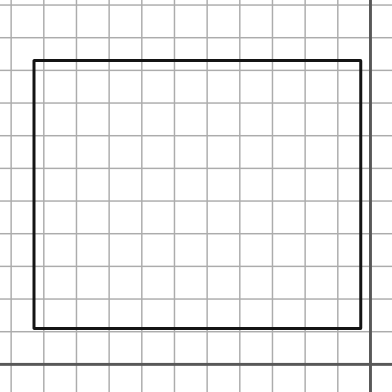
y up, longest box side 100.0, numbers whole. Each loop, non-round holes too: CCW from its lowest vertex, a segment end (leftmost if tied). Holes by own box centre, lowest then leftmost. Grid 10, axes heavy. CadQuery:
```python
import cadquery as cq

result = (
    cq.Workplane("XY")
    .moveTo(-103.0, 11.0)
    .lineTo(-3.0, 11.0)
    .lineTo(-3.0, 93.0)
    .lineTo(-103.0, 93.0)
    .close()
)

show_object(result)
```